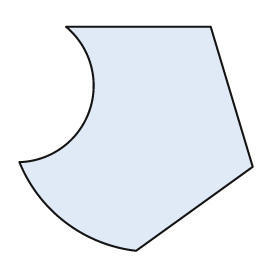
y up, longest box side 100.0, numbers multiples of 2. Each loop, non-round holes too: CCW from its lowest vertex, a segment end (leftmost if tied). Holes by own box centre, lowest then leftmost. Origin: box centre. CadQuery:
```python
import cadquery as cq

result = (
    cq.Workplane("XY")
    .moveTo(0.0, -48.0)
    .lineTo(50.0, -12.0)
    .lineTo(32.0, 48.0)
    .lineTo(-30.0, 48.0)
    .threePointArc((-20.0, 12.0), (-50.0, -10.0))
    .threePointArc((-30.0, -36.0), (0.0, -48.0))
    .close()
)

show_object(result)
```